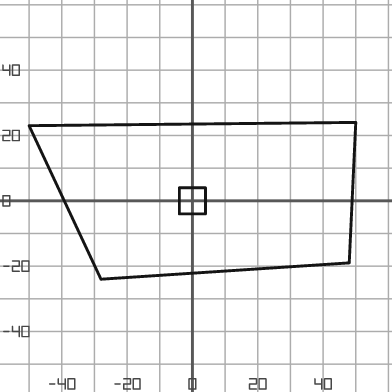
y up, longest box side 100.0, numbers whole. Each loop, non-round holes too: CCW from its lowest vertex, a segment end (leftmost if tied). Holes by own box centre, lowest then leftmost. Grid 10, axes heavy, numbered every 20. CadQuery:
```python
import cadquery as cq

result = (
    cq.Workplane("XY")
    .moveTo(-28.0, -24.0)
    .lineTo(48.0, -19.0)
    .lineTo(50.0, 24.0)
    .lineTo(-50.0, 23.0)
    .close()
    .moveTo(-4.0, -4.0)
    .lineTo(4.0, -4.0)
    .lineTo(4.0, 4.0)
    .lineTo(-4.0, 4.0)
    .close()
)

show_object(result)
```